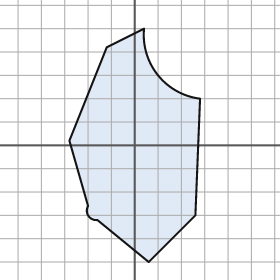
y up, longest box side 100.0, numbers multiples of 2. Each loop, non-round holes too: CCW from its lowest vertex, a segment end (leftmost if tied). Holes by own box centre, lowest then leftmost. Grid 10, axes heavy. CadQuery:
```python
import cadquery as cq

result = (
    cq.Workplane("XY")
    .moveTo(6.0, -50.0)
    .lineTo(26.0, -30.0)
    .lineTo(28.0, 20.0)
    .threePointArc((10.0, 30.0), (4.0, 50.0))
    .lineTo(-12.0, 42.0)
    .lineTo(-28.0, 2.0)
    .lineTo(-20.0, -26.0)
    .threePointArc((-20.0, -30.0), (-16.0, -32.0))
    .close()
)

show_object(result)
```